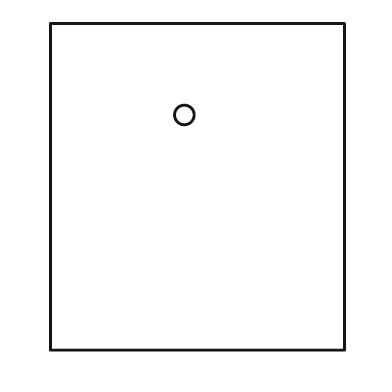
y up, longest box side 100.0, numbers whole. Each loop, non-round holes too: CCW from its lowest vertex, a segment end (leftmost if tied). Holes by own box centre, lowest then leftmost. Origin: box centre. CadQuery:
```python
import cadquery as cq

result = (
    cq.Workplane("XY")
    .moveTo(-45.0, -50.0)
    .lineTo(45.0, -50.0)
    .lineTo(45.0, 50.0)
    .lineTo(-45.0, 50.0)
    .close()
    .moveTo(-4.0, 22.0)
    .circle(3.0)
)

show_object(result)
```